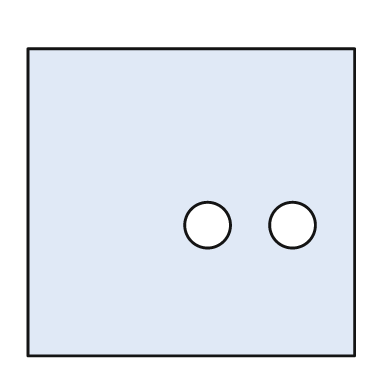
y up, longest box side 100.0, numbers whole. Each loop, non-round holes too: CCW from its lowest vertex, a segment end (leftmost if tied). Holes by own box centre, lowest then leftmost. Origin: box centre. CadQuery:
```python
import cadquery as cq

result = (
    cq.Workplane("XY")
    .moveTo(-50.0, -47.0)
    .lineTo(50.0, -47.0)
    .lineTo(50.0, 47.0)
    .lineTo(-50.0, 47.0)
    .close()
    .moveTo(5.0, -7.0)
    .circle(7.0)
    .moveTo(31.0, -7.0)
    .circle(7.0)
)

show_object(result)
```